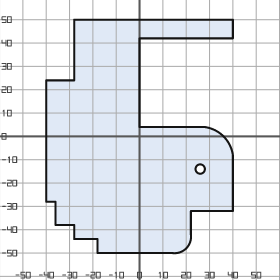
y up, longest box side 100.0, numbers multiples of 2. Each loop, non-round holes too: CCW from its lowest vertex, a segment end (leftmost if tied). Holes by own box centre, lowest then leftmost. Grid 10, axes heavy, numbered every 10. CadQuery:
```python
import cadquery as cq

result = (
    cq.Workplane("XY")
    .moveTo(-18.0, -50.0)
    .lineTo(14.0, -50.0)
    .threePointArc((20.0, -48.0), (22.0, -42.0))
    .lineTo(22.0, -32.0)
    .lineTo(40.0, -32.0)
    .lineTo(40.0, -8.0)
    .threePointArc((36.0, 0.0), (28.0, 4.0))
    .lineTo(0.0, 4.0)
    .lineTo(0.0, 42.0)
    .lineTo(40.0, 42.0)
    .lineTo(40.0, 50.0)
    .lineTo(-28.0, 50.0)
    .lineTo(-28.0, 24.0)
    .lineTo(-40.0, 24.0)
    .lineTo(-40.0, -28.0)
    .lineTo(-36.0, -28.0)
    .lineTo(-36.0, -38.0)
    .lineTo(-28.0, -38.0)
    .lineTo(-28.0, -44.0)
    .lineTo(-18.0, -44.0)
    .close()
    .moveTo(26.0, -14.0)
    .circle(2.0)
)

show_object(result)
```